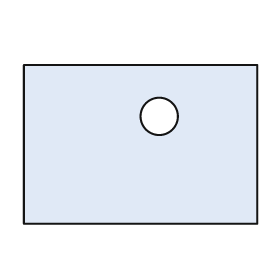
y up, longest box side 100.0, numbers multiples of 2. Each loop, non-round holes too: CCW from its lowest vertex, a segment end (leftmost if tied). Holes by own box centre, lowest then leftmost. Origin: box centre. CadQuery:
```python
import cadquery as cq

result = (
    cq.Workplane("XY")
    .moveTo(-50.0, -34.0)
    .lineTo(50.0, -34.0)
    .lineTo(50.0, 34.0)
    .lineTo(-50.0, 34.0)
    .close()
    .moveTo(8.0, 12.0)
    .circle(8.0)
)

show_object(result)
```